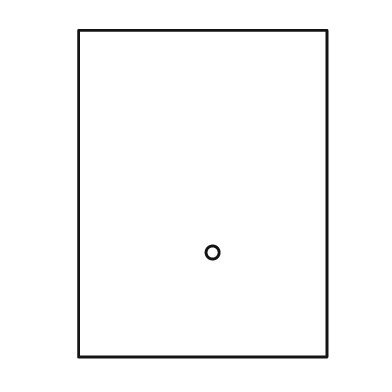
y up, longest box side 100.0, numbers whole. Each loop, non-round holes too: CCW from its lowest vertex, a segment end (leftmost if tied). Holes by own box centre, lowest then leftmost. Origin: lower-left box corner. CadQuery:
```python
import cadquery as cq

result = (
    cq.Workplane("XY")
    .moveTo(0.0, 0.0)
    .lineTo(76.0, 0.0)
    .lineTo(76.0, 100.0)
    .lineTo(0.0, 100.0)
    .close()
    .moveTo(41.0, 32.0)
    .circle(2.0)
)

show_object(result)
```